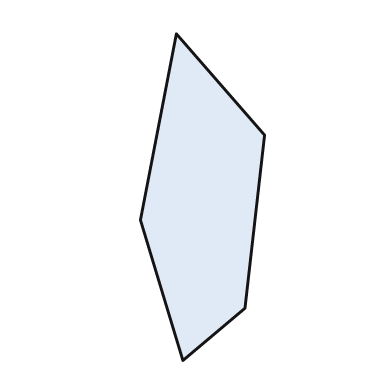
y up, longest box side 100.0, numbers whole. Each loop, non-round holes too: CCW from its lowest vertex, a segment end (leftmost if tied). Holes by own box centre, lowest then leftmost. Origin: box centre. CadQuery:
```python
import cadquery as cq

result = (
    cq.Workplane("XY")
    .moveTo(-6.0, -50.0)
    .lineTo(13.0, -34.0)
    .lineTo(19.0, 19.0)
    .lineTo(-8.0, 50.0)
    .lineTo(-19.0, -7.0)
    .close()
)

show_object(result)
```